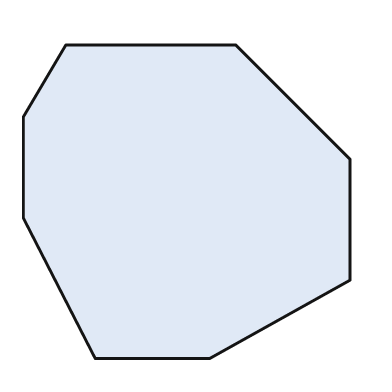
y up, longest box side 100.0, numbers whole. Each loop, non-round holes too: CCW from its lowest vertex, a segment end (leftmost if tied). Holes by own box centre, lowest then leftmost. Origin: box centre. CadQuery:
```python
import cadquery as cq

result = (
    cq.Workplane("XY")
    .moveTo(-28.0, -48.0)
    .lineTo(7.0, -48.0)
    .lineTo(50.0, -24.0)
    .lineTo(50.0, 13.0)
    .lineTo(15.0, 48.0)
    .lineTo(-37.0, 48.0)
    .lineTo(-50.0, 26.0)
    .lineTo(-50.0, -5.0)
    .close()
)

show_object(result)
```